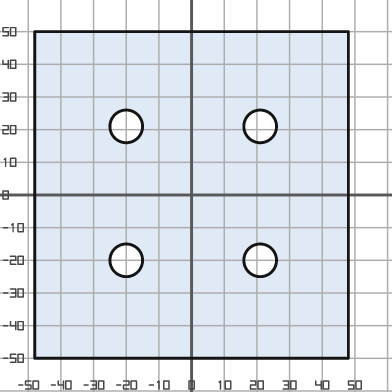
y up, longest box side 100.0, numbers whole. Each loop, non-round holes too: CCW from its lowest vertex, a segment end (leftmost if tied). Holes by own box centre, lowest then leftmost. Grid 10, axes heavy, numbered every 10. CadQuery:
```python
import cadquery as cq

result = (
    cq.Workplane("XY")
    .moveTo(-48.0, -50.0)
    .lineTo(48.0, -50.0)
    .lineTo(48.0, 50.0)
    .lineTo(-48.0, 50.0)
    .close()
    .moveTo(-20.0, -20.0)
    .circle(5.0)
    .moveTo(21.0, -20.0)
    .circle(5.0)
    .moveTo(-20.0, 21.0)
    .circle(5.0)
    .moveTo(21.0, 21.0)
    .circle(5.0)
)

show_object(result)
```